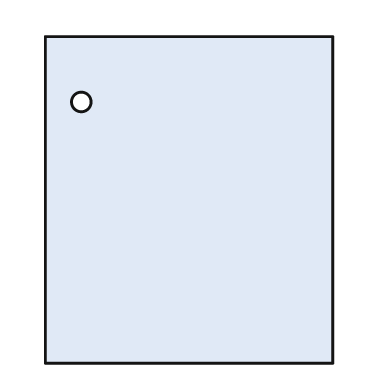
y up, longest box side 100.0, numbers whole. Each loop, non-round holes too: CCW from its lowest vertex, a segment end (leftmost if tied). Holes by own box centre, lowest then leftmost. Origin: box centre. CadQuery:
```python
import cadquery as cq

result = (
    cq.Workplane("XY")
    .moveTo(-44.0, -50.0)
    .lineTo(44.0, -50.0)
    .lineTo(44.0, 50.0)
    .lineTo(-44.0, 50.0)
    .close()
    .moveTo(-33.0, 30.0)
    .circle(3.0)
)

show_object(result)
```